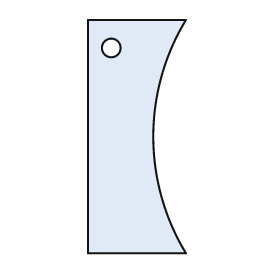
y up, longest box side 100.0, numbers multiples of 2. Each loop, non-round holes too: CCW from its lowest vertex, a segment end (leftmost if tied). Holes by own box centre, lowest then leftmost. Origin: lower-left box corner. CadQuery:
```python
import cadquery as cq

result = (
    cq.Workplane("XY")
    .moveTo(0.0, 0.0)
    .lineTo(42.0, 0.0)
    .threePointArc((28.0, 50.0), (42.0, 100.0))
    .lineTo(0.0, 100.0)
    .close()
    .moveTo(10.0, 88.0)
    .circle(4.0)
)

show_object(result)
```